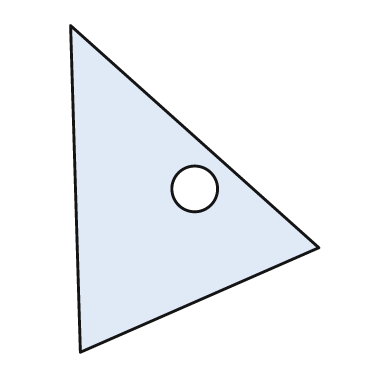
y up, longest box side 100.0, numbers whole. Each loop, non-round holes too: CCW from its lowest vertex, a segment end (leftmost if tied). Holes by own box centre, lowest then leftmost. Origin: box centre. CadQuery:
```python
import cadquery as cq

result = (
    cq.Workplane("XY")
    .moveTo(-35.0, -50.0)
    .lineTo(38.0, -18.0)
    .lineTo(-38.0, 50.0)
    .close()
    .moveTo(0.0, 0.0)
    .circle(7.0)
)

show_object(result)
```